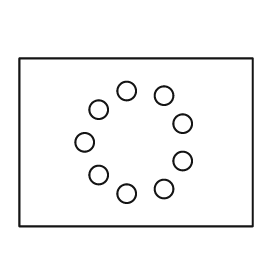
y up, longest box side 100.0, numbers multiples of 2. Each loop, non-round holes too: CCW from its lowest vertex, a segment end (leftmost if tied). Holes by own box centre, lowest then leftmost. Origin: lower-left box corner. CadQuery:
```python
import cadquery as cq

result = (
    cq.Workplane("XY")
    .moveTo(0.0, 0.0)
    .lineTo(100.0, 0.0)
    .lineTo(100.0, 72.0)
    .lineTo(0.0, 72.0)
    .close()
    .moveTo(46.0, 14.0)
    .circle(4.0)
    .moveTo(62.0, 16.0)
    .circle(4.0)
    .moveTo(34.0, 22.0)
    .circle(4.0)
    .moveTo(70.0, 28.0)
    .circle(4.0)
    .moveTo(28.0, 36.0)
    .circle(4.0)
    .moveTo(70.0, 44.0)
    .circle(4.0)
    .moveTo(34.0, 50.0)
    .circle(4.0)
    .moveTo(62.0, 56.0)
    .circle(4.0)
    .moveTo(46.0, 58.0)
    .circle(4.0)
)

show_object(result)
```